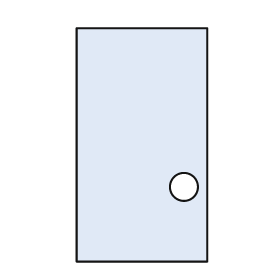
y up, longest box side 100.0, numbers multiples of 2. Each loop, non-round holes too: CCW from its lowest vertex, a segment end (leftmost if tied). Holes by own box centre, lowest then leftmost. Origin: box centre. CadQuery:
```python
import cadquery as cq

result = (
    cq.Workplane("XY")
    .moveTo(-28.0, -50.0)
    .lineTo(28.0, -50.0)
    .lineTo(28.0, 50.0)
    .lineTo(-28.0, 50.0)
    .close()
    .moveTo(18.0, -18.0)
    .circle(6.0)
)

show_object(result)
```